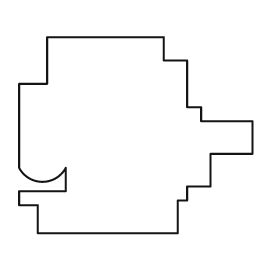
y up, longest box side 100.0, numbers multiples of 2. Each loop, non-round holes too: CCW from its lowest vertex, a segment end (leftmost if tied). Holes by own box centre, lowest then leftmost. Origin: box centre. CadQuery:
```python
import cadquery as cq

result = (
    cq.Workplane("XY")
    .moveTo(-42.0, -42.0)
    .lineTo(18.0, -42.0)
    .lineTo(18.0, -28.0)
    .lineTo(22.0, -28.0)
    .lineTo(22.0, -22.0)
    .lineTo(32.0, -22.0)
    .lineTo(32.0, -8.0)
    .lineTo(50.0, -8.0)
    .lineTo(50.0, 6.0)
    .lineTo(28.0, 6.0)
    .lineTo(28.0, 12.0)
    .lineTo(22.0, 12.0)
    .lineTo(22.0, 32.0)
    .lineTo(12.0, 32.0)
    .lineTo(12.0, 42.0)
    .lineTo(-38.0, 42.0)
    .lineTo(-38.0, 22.0)
    .lineTo(-50.0, 22.0)
    .lineTo(-50.0, -14.0)
    .threePointArc((-40.0, -20.0), (-30.0, -14.0))
    .lineTo(-30.0, -24.0)
    .lineTo(-50.0, -24.0)
    .lineTo(-50.0, -30.0)
    .lineTo(-42.0, -30.0)
    .close()
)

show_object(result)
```